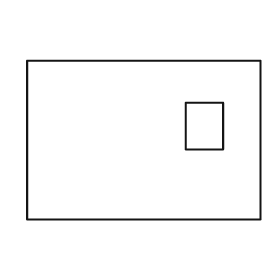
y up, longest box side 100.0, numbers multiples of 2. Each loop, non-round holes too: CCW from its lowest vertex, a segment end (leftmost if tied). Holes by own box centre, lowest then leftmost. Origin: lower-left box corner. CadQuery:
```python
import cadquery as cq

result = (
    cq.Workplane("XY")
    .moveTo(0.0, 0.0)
    .lineTo(100.0, 0.0)
    .lineTo(100.0, 68.0)
    .lineTo(0.0, 68.0)
    .close()
    .moveTo(68.0, 30.0)
    .lineTo(84.0, 30.0)
    .lineTo(84.0, 50.0)
    .lineTo(68.0, 50.0)
    .close()
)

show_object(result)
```